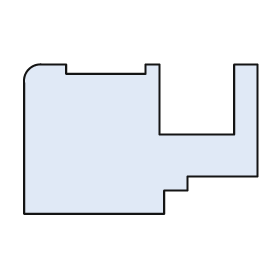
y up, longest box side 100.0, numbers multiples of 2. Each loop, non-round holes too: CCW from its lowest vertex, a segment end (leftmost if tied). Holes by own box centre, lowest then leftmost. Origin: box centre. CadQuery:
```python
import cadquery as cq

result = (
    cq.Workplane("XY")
    .moveTo(-50.0, -32.0)
    .lineTo(10.0, -32.0)
    .lineTo(10.0, -22.0)
    .lineTo(20.0, -22.0)
    .lineTo(20.0, -16.0)
    .lineTo(50.0, -16.0)
    .lineTo(50.0, 32.0)
    .lineTo(40.0, 32.0)
    .lineTo(40.0, 2.0)
    .lineTo(8.0, 2.0)
    .lineTo(8.0, 32.0)
    .lineTo(2.0, 32.0)
    .lineTo(2.0, 28.0)
    .lineTo(-32.0, 28.0)
    .lineTo(-32.0, 32.0)
    .lineTo(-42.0, 32.0)
    .threePointArc((-48.0, 30.0), (-50.0, 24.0))
    .close()
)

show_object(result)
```